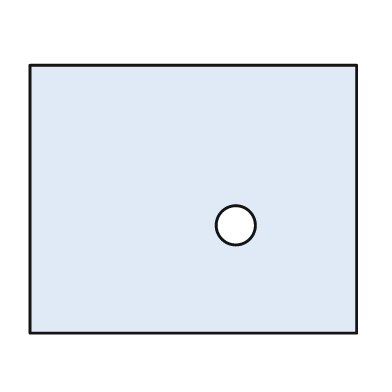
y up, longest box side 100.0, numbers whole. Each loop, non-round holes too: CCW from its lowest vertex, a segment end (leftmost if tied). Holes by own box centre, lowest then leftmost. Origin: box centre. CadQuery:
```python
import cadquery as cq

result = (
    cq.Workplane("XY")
    .moveTo(-50.0, -41.0)
    .lineTo(50.0, -41.0)
    .lineTo(50.0, 41.0)
    .lineTo(-50.0, 41.0)
    .close()
    .moveTo(13.0, -8.0)
    .circle(6.0)
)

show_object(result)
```